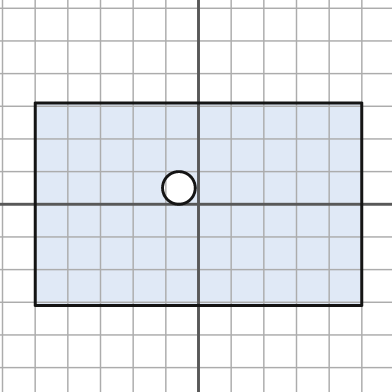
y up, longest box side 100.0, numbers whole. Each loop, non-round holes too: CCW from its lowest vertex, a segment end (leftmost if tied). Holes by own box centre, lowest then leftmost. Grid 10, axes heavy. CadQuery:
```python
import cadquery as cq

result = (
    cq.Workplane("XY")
    .moveTo(-50.0, -31.0)
    .lineTo(50.0, -31.0)
    .lineTo(50.0, 31.0)
    .lineTo(-50.0, 31.0)
    .close()
    .moveTo(-6.0, 5.0)
    .circle(5.0)
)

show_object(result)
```